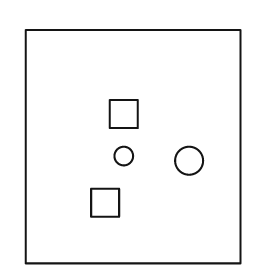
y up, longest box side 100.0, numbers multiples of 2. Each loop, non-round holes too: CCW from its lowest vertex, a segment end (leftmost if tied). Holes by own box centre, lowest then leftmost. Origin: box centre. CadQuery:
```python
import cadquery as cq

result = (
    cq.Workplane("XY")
    .moveTo(-46.0, -50.0)
    .lineTo(46.0, -50.0)
    .lineTo(46.0, 50.0)
    .lineTo(-46.0, 50.0)
    .close()
    .moveTo(-18.0, -30.0)
    .lineTo(-6.0, -30.0)
    .lineTo(-6.0, -18.0)
    .lineTo(-18.0, -18.0)
    .close()
    .moveTo(24.0, -6.0)
    .circle(6.0)
    .moveTo(-4.0, -4.0)
    .circle(4.0)
    .moveTo(-10.0, 8.0)
    .lineTo(2.0, 8.0)
    .lineTo(2.0, 20.0)
    .lineTo(-10.0, 20.0)
    .close()
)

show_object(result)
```